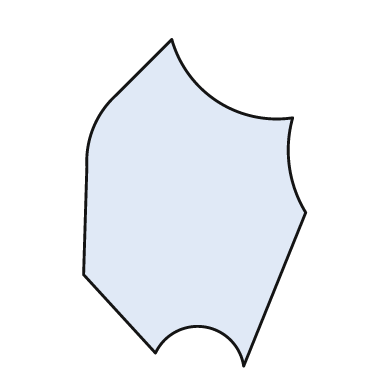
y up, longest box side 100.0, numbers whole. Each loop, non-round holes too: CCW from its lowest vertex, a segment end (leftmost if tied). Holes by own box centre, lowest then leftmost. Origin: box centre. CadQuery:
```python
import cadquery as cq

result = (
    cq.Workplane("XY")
    .moveTo(15.0, -50.0)
    .lineTo(34.0, -3.0)
    .threePointArc((29.0, 11.0), (30.0, 26.0))
    .threePointArc((7.0, 31.0), (-7.0, 50.0))
    .lineTo(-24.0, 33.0)
    .threePointArc((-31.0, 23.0), (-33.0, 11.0))
    .lineTo(-34.0, -22.0)
    .lineTo(-12.0, -46.0)
    .threePointArc((3.0, -38.0), (15.0, -50.0))
    .close()
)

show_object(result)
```